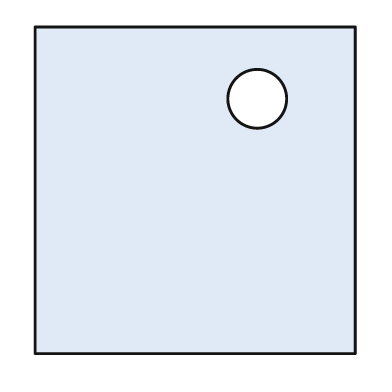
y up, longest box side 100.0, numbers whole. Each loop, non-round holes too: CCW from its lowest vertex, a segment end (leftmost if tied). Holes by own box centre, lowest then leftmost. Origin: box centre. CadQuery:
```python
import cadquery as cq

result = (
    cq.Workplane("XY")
    .moveTo(-49.0, -50.0)
    .lineTo(49.0, -50.0)
    .lineTo(49.0, 50.0)
    .lineTo(-49.0, 50.0)
    .close()
    .moveTo(19.0, 28.0)
    .circle(9.0)
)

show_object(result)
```